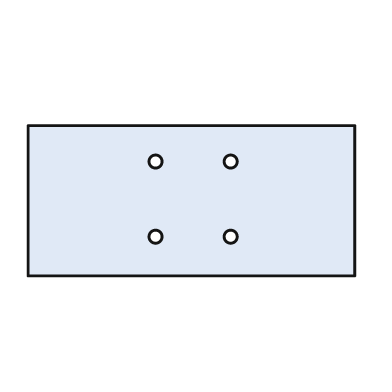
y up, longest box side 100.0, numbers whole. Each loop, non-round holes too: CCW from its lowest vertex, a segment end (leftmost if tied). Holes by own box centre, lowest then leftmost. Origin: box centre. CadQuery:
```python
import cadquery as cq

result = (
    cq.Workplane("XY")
    .moveTo(-50.0, -23.0)
    .lineTo(50.0, -23.0)
    .lineTo(50.0, 23.0)
    .lineTo(-50.0, 23.0)
    .close()
    .moveTo(-11.0, -11.0)
    .circle(2.0)
    .moveTo(12.0, -11.0)
    .circle(2.0)
    .moveTo(-11.0, 12.0)
    .circle(2.0)
    .moveTo(12.0, 12.0)
    .circle(2.0)
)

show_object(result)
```